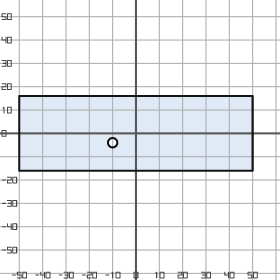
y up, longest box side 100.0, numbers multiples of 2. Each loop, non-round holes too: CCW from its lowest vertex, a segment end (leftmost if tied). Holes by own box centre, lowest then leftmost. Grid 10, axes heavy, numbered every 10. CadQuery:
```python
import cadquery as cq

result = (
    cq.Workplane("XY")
    .moveTo(-50.0, -16.0)
    .lineTo(50.0, -16.0)
    .lineTo(50.0, 16.0)
    .lineTo(-50.0, 16.0)
    .close()
    .moveTo(-10.0, -4.0)
    .circle(2.0)
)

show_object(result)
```